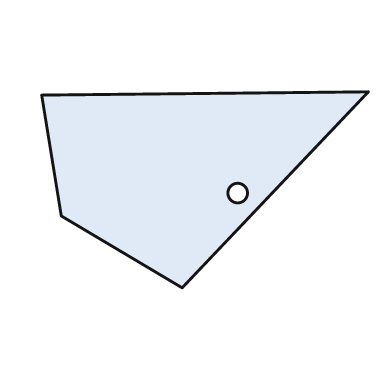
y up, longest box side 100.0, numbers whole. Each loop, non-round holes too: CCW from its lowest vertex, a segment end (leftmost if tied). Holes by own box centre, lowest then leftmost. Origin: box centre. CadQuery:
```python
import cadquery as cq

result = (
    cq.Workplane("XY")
    .moveTo(-7.0, -30.0)
    .lineTo(50.0, 30.0)
    .lineTo(-50.0, 29.0)
    .lineTo(-44.0, -8.0)
    .close()
    .moveTo(10.0, -1.0)
    .circle(3.0)
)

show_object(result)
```